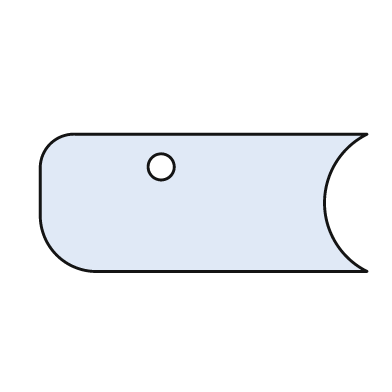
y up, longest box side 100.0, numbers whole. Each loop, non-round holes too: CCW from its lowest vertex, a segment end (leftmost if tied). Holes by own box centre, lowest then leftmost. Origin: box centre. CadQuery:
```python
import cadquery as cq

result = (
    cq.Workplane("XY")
    .moveTo(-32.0, -21.0)
    .lineTo(50.0, -21.0)
    .threePointArc((37.0, 0.0), (50.0, 21.0))
    .lineTo(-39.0, 21.0)
    .threePointArc((-47.0, 18.0), (-50.0, 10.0))
    .lineTo(-50.0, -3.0)
    .threePointArc((-45.0, -16.0), (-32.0, -21.0))
    .close()
    .moveTo(-13.0, 11.0)
    .circle(4.0)
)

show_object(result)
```